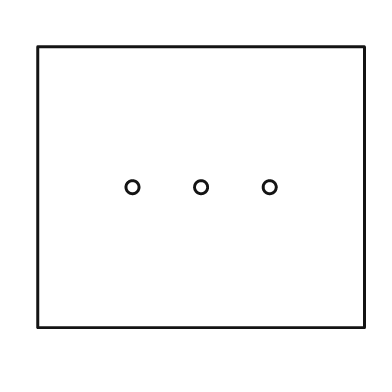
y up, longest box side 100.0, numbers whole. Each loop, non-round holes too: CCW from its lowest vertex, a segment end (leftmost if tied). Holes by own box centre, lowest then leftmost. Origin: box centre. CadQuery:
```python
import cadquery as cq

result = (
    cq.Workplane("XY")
    .moveTo(-50.0, -43.0)
    .lineTo(50.0, -43.0)
    .lineTo(50.0, 43.0)
    .lineTo(-50.0, 43.0)
    .close()
    .moveTo(-21.0, 0.0)
    .circle(2.0)
    .moveTo(0.0, 0.0)
    .circle(2.0)
    .moveTo(21.0, 0.0)
    .circle(2.0)
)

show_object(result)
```